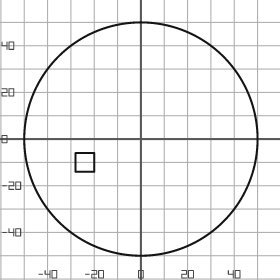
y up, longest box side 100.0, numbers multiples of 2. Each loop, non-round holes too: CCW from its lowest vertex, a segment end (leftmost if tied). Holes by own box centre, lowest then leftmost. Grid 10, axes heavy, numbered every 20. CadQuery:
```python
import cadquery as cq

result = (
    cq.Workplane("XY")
    .moveTo(0.0, 0.0)
    .circle(50.0)
    .moveTo(-28.0, -14.0)
    .lineTo(-20.0, -14.0)
    .lineTo(-20.0, -6.0)
    .lineTo(-28.0, -6.0)
    .close()
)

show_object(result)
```